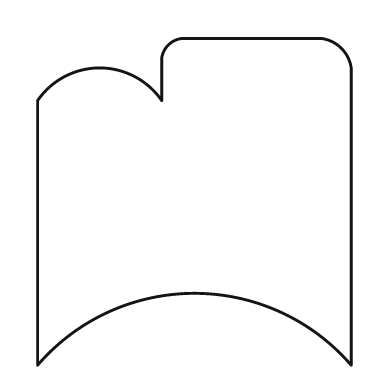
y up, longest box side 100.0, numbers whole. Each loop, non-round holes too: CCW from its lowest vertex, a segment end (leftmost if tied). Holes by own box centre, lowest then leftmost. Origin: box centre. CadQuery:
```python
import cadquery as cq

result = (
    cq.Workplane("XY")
    .moveTo(-48.0, -50.0)
    .threePointArc((0.0, -28.0), (48.0, -50.0))
    .lineTo(48.0, 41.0)
    .threePointArc((45.0, 47.0), (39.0, 50.0))
    .lineTo(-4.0, 50.0)
    .threePointArc((-8.0, 48.0), (-10.0, 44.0))
    .lineTo(-10.0, 31.0)
    .threePointArc((-29.0, 41.0), (-48.0, 31.0))
    .close()
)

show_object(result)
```